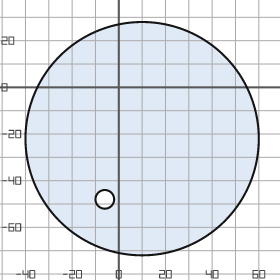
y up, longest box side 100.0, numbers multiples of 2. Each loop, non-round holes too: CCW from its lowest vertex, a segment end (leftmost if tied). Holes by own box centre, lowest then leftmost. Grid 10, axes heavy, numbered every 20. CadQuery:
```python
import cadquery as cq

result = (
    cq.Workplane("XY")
    .moveTo(10.0, -22.0)
    .circle(50.0)
    .moveTo(-6.0, -48.0)
    .circle(4.0)
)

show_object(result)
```